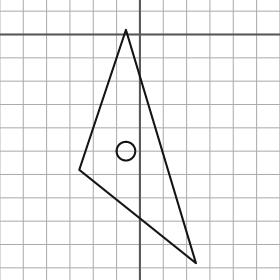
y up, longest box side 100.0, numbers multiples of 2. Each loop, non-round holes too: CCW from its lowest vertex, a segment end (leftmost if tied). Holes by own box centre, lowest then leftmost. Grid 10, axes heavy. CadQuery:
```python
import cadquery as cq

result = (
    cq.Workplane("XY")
    .moveTo(24.0, -98.0)
    .lineTo(-6.0, 2.0)
    .lineTo(-26.0, -58.0)
    .close()
    .moveTo(-6.0, -50.0)
    .circle(4.0)
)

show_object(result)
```